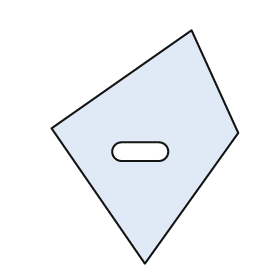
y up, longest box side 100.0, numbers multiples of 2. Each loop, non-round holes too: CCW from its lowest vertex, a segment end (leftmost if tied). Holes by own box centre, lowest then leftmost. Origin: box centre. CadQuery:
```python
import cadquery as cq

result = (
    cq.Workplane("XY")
    .moveTo(0.0, -50.0)
    .lineTo(40.0, 6.0)
    .lineTo(20.0, 50.0)
    .lineTo(-40.0, 8.0)
    .close()
    .moveTo(-10.0, -6.0)
    .lineTo(6.0, -6.0)
    .threePointArc((10.0, -2.0), (6.0, 2.0))
    .lineTo(-10.0, 2.0)
    .threePointArc((-14.0, -2.0), (-10.0, -6.0))
    .close()
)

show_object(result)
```